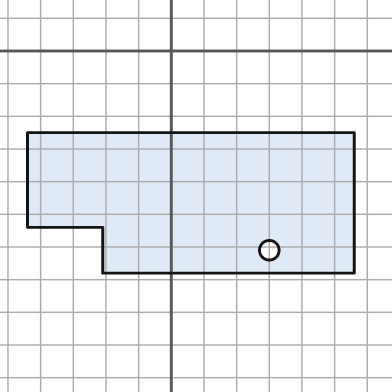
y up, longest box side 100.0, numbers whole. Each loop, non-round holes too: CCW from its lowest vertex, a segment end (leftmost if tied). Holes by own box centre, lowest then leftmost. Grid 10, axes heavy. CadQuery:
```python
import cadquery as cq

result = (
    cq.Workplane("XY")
    .moveTo(-21.0, -68.0)
    .lineTo(56.0, -68.0)
    .lineTo(56.0, -25.0)
    .lineTo(-44.0, -25.0)
    .lineTo(-44.0, -54.0)
    .lineTo(-21.0, -54.0)
    .close()
    .moveTo(30.0, -61.0)
    .circle(3.0)
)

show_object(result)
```